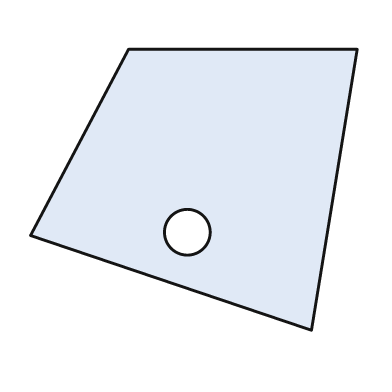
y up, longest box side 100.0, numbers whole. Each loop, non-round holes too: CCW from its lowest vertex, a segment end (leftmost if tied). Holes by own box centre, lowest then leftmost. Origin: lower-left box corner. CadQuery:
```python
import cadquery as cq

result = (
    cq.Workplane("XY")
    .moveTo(86.0, 0.0)
    .lineTo(100.0, 86.0)
    .lineTo(30.0, 86.0)
    .lineTo(0.0, 29.0)
    .close()
    .moveTo(48.0, 30.0)
    .circle(7.0)
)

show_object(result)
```